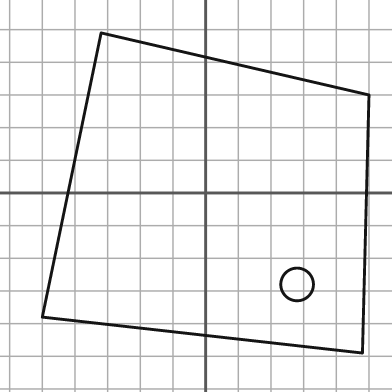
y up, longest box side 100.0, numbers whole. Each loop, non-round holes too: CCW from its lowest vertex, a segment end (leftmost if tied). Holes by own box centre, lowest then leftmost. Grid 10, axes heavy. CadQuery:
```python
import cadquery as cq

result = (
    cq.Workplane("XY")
    .moveTo(48.0, -49.0)
    .lineTo(50.0, 30.0)
    .lineTo(-32.0, 49.0)
    .lineTo(-50.0, -38.0)
    .close()
    .moveTo(28.0, -28.0)
    .circle(5.0)
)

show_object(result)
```